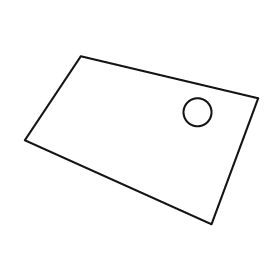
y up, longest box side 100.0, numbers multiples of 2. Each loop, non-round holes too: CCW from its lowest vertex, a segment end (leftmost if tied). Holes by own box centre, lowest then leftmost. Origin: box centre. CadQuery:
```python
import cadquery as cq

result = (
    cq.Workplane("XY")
    .moveTo(30.0, -36.0)
    .lineTo(50.0, 18.0)
    .lineTo(-26.0, 36.0)
    .lineTo(-50.0, 0.0)
    .close()
    .moveTo(24.0, 12.0)
    .circle(6.0)
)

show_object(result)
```